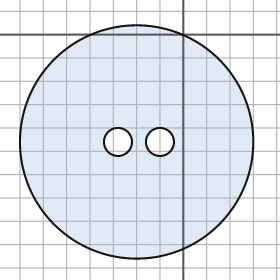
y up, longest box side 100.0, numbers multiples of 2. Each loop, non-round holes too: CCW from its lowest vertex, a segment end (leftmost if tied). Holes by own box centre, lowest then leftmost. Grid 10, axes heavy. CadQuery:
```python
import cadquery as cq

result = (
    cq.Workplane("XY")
    .moveTo(-20.0, -46.0)
    .circle(50.0)
    .moveTo(-28.0, -46.0)
    .circle(6.0)
    .moveTo(-10.0, -46.0)
    .circle(6.0)
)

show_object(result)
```